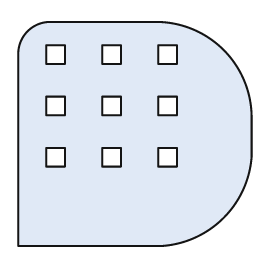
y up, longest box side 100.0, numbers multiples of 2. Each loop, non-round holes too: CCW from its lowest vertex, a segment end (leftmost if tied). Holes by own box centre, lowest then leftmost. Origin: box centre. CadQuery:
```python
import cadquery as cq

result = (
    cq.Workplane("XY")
    .moveTo(-50.0, -48.0)
    .lineTo(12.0, -48.0)
    .threePointArc((38.0, -36.0), (50.0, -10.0))
    .lineTo(50.0, 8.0)
    .threePointArc((38.0, 36.0), (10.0, 48.0))
    .lineTo(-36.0, 48.0)
    .threePointArc((-46.0, 44.0), (-50.0, 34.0))
    .close()
    .moveTo(-38.0, -14.0)
    .lineTo(-30.0, -14.0)
    .lineTo(-30.0, -6.0)
    .lineTo(-38.0, -6.0)
    .close()
    .moveTo(-14.0, -14.0)
    .lineTo(-6.0, -14.0)
    .lineTo(-6.0, -6.0)
    .lineTo(-14.0, -6.0)
    .close()
    .moveTo(10.0, -14.0)
    .lineTo(18.0, -14.0)
    .lineTo(18.0, -6.0)
    .lineTo(10.0, -6.0)
    .close()
    .moveTo(-38.0, 8.0)
    .lineTo(-30.0, 8.0)
    .lineTo(-30.0, 16.0)
    .lineTo(-38.0, 16.0)
    .close()
    .moveTo(-14.0, 8.0)
    .lineTo(-6.0, 8.0)
    .lineTo(-6.0, 16.0)
    .lineTo(-14.0, 16.0)
    .close()
    .moveTo(10.0, 8.0)
    .lineTo(18.0, 8.0)
    .lineTo(18.0, 16.0)
    .lineTo(10.0, 16.0)
    .close()
    .moveTo(-38.0, 30.0)
    .lineTo(-30.0, 30.0)
    .lineTo(-30.0, 38.0)
    .lineTo(-38.0, 38.0)
    .close()
    .moveTo(-14.0, 30.0)
    .lineTo(-6.0, 30.0)
    .lineTo(-6.0, 38.0)
    .lineTo(-14.0, 38.0)
    .close()
    .moveTo(10.0, 30.0)
    .lineTo(18.0, 30.0)
    .lineTo(18.0, 38.0)
    .lineTo(10.0, 38.0)
    .close()
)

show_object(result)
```